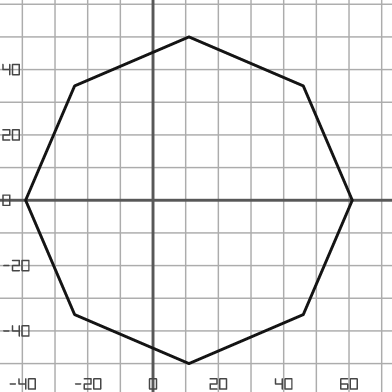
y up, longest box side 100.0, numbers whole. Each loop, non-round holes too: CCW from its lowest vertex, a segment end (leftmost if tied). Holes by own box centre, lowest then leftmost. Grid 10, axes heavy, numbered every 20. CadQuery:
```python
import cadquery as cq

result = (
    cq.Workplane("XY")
    .moveTo(11.0, -50.0)
    .lineTo(46.0, -35.0)
    .lineTo(61.0, 0.0)
    .lineTo(46.0, 35.0)
    .lineTo(11.0, 50.0)
    .lineTo(-24.0, 35.0)
    .lineTo(-39.0, 0.0)
    .lineTo(-24.0, -35.0)
    .close()
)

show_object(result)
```